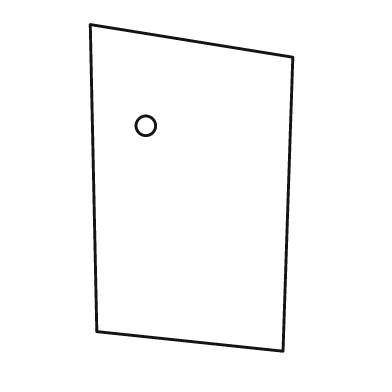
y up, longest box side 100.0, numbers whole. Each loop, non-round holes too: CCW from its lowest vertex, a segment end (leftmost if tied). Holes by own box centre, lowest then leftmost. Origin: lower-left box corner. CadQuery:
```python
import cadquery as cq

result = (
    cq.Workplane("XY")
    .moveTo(59.0, 0.0)
    .lineTo(62.0, 90.0)
    .lineTo(0.0, 100.0)
    .lineTo(2.0, 6.0)
    .close()
    .moveTo(17.0, 69.0)
    .circle(3.0)
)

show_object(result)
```